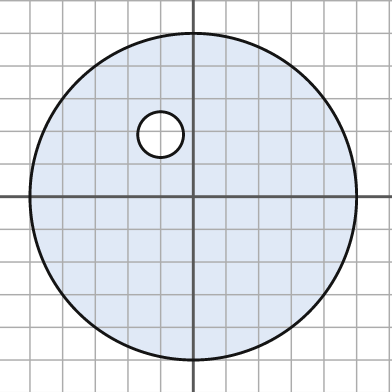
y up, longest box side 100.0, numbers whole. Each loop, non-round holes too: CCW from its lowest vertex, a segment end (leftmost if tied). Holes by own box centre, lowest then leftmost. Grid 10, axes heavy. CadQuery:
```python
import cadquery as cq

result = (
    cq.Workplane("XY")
    .moveTo(0.0, 0.0)
    .circle(50.0)
    .moveTo(-10.0, 19.0)
    .circle(7.0)
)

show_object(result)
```